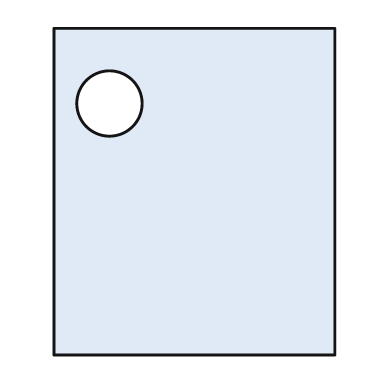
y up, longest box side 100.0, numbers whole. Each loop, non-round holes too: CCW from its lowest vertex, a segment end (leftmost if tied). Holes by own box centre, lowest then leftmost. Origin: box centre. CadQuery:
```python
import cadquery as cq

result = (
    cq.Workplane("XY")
    .moveTo(-43.0, -50.0)
    .lineTo(43.0, -50.0)
    .lineTo(43.0, 50.0)
    .lineTo(-43.0, 50.0)
    .close()
    .moveTo(-26.0, 27.0)
    .circle(10.0)
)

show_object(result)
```